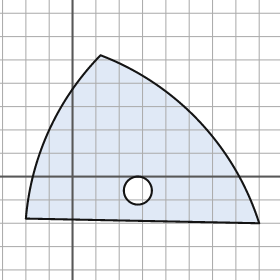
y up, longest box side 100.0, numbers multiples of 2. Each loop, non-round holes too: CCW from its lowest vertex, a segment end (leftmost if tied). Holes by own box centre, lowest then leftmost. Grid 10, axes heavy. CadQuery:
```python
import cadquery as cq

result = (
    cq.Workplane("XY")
    .moveTo(80.0, -20.0)
    .threePointArc((54.0, 24.0), (12.0, 52.0))
    .threePointArc((-10.0, 20.0), (-20.0, -18.0))
    .close()
    .moveTo(28.0, -6.0)
    .circle(6.0)
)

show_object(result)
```